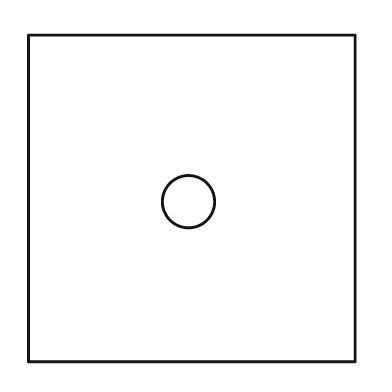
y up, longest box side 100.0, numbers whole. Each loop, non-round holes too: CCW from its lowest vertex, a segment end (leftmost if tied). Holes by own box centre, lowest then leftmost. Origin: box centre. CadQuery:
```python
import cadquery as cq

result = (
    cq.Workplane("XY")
    .moveTo(-50.0, -50.0)
    .lineTo(50.0, -50.0)
    .lineTo(50.0, 50.0)
    .lineTo(-50.0, 50.0)
    .close()
    .moveTo(-1.0, -1.0)
    .circle(8.0)
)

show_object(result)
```